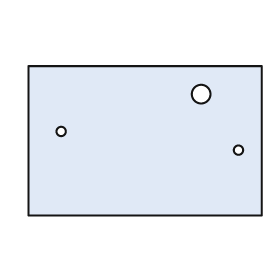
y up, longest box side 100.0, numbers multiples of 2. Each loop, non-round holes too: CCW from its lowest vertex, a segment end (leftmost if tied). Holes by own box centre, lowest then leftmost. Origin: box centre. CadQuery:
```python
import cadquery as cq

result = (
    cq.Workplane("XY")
    .moveTo(-50.0, -32.0)
    .lineTo(50.0, -32.0)
    .lineTo(50.0, 32.0)
    .lineTo(-50.0, 32.0)
    .close()
    .moveTo(40.0, -4.0)
    .circle(2.0)
    .moveTo(-36.0, 4.0)
    .circle(2.0)
    .moveTo(24.0, 20.0)
    .circle(4.0)
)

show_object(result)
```